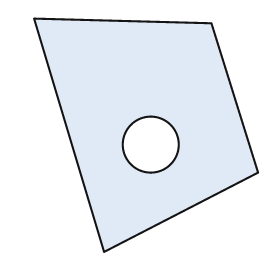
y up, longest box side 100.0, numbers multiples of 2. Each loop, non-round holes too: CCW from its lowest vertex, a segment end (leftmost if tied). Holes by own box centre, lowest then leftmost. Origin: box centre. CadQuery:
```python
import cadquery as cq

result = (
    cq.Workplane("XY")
    .moveTo(-18.0, -50.0)
    .lineTo(48.0, -16.0)
    .lineTo(28.0, 48.0)
    .lineTo(-48.0, 50.0)
    .close()
    .moveTo(2.0, -4.0)
    .circle(12.0)
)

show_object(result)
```